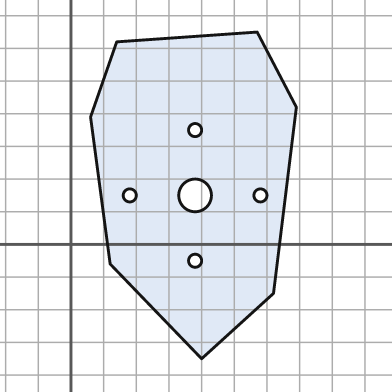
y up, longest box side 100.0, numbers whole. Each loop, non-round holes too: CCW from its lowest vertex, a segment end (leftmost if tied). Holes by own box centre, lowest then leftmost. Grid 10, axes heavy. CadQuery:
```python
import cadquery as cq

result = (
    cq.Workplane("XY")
    .moveTo(40.0, -35.0)
    .lineTo(62.0, -15.0)
    .lineTo(69.0, 42.0)
    .lineTo(57.0, 65.0)
    .lineTo(14.0, 62.0)
    .lineTo(6.0, 39.0)
    .lineTo(12.0, -6.0)
    .close()
    .moveTo(38.0, -5.0)
    .circle(2.0)
    .moveTo(18.0, 15.0)
    .circle(2.0)
    .moveTo(38.0, 15.0)
    .circle(5.0)
    .moveTo(58.0, 15.0)
    .circle(2.0)
    .moveTo(38.0, 35.0)
    .circle(2.0)
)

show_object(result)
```